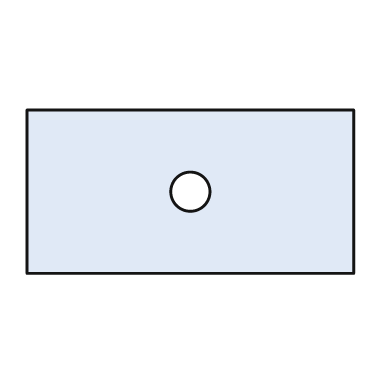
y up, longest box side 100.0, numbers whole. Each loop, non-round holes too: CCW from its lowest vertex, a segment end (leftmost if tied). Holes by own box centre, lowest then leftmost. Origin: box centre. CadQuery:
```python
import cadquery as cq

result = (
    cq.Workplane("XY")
    .moveTo(-50.0, -25.0)
    .lineTo(50.0, -25.0)
    .lineTo(50.0, 25.0)
    .lineTo(-50.0, 25.0)
    .close()
    .moveTo(0.0, 0.0)
    .circle(6.0)
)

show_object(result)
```